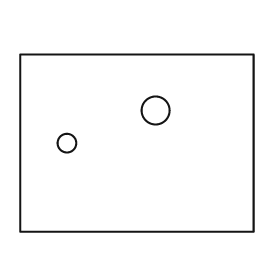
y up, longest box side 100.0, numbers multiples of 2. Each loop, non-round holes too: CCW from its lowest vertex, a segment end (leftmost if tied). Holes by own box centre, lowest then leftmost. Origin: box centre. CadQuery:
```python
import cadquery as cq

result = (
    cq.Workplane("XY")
    .moveTo(-50.0, -38.0)
    .lineTo(50.0, -38.0)
    .lineTo(50.0, 38.0)
    .lineTo(-50.0, 38.0)
    .close()
    .moveTo(-30.0, 0.0)
    .circle(4.0)
    .moveTo(8.0, 14.0)
    .circle(6.0)
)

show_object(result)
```